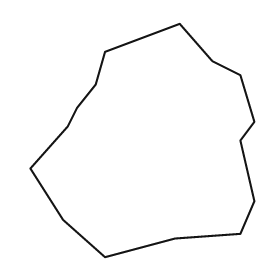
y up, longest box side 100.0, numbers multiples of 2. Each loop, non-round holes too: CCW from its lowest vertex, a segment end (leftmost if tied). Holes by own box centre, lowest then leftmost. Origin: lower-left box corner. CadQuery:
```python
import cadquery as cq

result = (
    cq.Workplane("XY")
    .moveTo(32.0, 0.0)
    .lineTo(62.0, 8.0)
    .lineTo(90.0, 10.0)
    .lineTo(96.0, 24.0)
    .lineTo(90.0, 50.0)
    .lineTo(96.0, 58.0)
    .lineTo(90.0, 78.0)
    .lineTo(78.0, 84.0)
    .lineTo(64.0, 100.0)
    .lineTo(32.0, 88.0)
    .lineTo(28.0, 74.0)
    .lineTo(20.0, 64.0)
    .lineTo(16.0, 56.0)
    .lineTo(0.0, 38.0)
    .lineTo(14.0, 16.0)
    .close()
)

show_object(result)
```